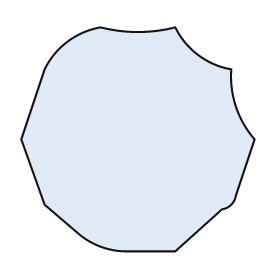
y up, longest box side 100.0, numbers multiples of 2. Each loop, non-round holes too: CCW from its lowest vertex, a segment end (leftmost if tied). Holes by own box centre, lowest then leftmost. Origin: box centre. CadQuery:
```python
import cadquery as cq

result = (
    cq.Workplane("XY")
    .moveTo(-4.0, -48.0)
    .lineTo(16.0, -48.0)
    .lineTo(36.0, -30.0)
    .threePointArc((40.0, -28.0), (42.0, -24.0))
    .lineTo(50.0, 0.0)
    .threePointArc((42.0, 14.0), (40.0, 30.0))
    .threePointArc((26.0, 36.0), (16.0, 48.0))
    .threePointArc((0.0, 46.0), (-16.0, 48.0))
    .threePointArc((-30.0, 42.0), (-40.0, 30.0))
    .lineTo(-50.0, 0.0)
    .lineTo(-40.0, -28.0)
    .lineTo(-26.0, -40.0)
    .threePointArc((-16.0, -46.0), (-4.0, -48.0))
    .close()
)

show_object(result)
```